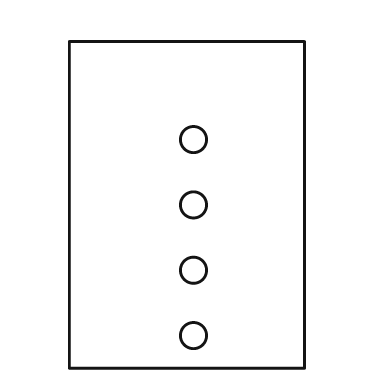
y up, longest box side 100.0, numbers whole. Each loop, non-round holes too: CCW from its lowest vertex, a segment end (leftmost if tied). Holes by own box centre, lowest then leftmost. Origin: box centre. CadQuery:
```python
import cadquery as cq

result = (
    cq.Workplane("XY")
    .moveTo(-36.0, -50.0)
    .lineTo(36.0, -50.0)
    .lineTo(36.0, 50.0)
    .lineTo(-36.0, 50.0)
    .close()
    .moveTo(2.0, -40.0)
    .circle(4.0)
    .moveTo(2.0, -20.0)
    .circle(4.0)
    .moveTo(2.0, 0.0)
    .circle(4.0)
    .moveTo(2.0, 20.0)
    .circle(4.0)
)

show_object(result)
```